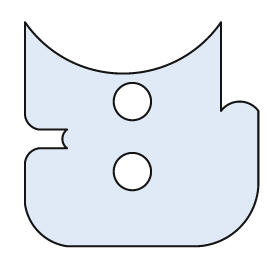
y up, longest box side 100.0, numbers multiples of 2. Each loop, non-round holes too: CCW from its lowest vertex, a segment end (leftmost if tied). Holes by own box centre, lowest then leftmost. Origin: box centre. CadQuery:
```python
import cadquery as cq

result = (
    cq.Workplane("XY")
    .moveTo(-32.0, -48.0)
    .lineTo(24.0, -48.0)
    .threePointArc((42.0, -40.0), (50.0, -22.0))
    .lineTo(50.0, 10.0)
    .threePointArc((42.0, 14.0), (34.0, 10.0))
    .lineTo(34.0, 48.0)
    .threePointArc((-8.0, 26.0), (-50.0, 48.0))
    .lineTo(-50.0, 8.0)
    .threePointArc((-48.0, 4.0), (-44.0, 2.0))
    .lineTo(-32.0, 2.0)
    .threePointArc((-34.0, -2.0), (-32.0, -6.0))
    .lineTo(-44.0, -6.0)
    .threePointArc((-48.0, -8.0), (-50.0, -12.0))
    .lineTo(-50.0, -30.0)
    .threePointArc((-44.0, -42.0), (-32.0, -48.0))
    .close()
    .moveTo(-4.0, -16.0)
    .circle(8.0)
    .moveTo(-4.0, 14.0)
    .circle(8.0)
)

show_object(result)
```